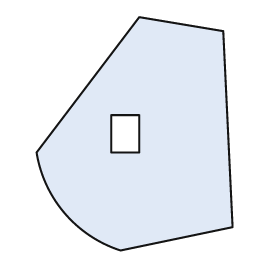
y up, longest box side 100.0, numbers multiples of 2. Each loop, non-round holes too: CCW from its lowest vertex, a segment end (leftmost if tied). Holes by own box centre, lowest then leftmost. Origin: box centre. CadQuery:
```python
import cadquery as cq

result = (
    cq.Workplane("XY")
    .moveTo(-6.0, -50.0)
    .lineTo(42.0, -40.0)
    .lineTo(38.0, 44.0)
    .lineTo(2.0, 50.0)
    .lineTo(-42.0, -8.0)
    .threePointArc((-30.0, -34.0), (-6.0, -50.0))
    .close()
    .moveTo(-10.0, -8.0)
    .lineTo(2.0, -8.0)
    .lineTo(2.0, 8.0)
    .lineTo(-10.0, 8.0)
    .close()
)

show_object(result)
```